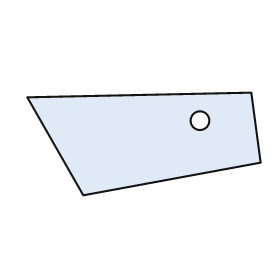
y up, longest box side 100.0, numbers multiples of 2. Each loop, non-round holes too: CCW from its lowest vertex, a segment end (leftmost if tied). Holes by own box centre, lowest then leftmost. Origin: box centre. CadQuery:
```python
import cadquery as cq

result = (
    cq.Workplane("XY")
    .moveTo(-26.0, -22.0)
    .lineTo(50.0, -8.0)
    .lineTo(46.0, 22.0)
    .lineTo(-50.0, 20.0)
    .close()
    .moveTo(24.0, 10.0)
    .circle(4.0)
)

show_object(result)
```